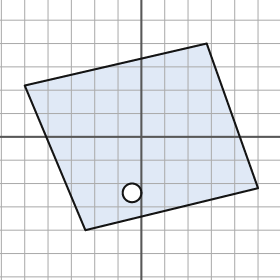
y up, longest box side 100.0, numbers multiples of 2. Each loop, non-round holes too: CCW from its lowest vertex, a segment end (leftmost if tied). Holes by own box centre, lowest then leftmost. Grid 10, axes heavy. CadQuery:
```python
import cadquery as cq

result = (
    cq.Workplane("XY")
    .moveTo(-24.0, -40.0)
    .lineTo(50.0, -22.0)
    .lineTo(28.0, 40.0)
    .lineTo(-50.0, 22.0)
    .close()
    .moveTo(-4.0, -24.0)
    .circle(4.0)
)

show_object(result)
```